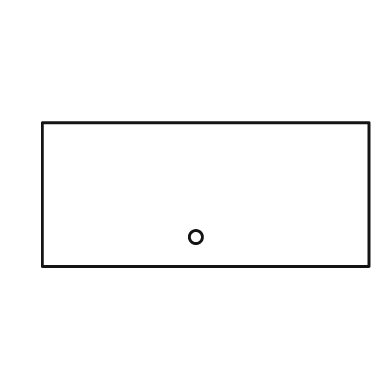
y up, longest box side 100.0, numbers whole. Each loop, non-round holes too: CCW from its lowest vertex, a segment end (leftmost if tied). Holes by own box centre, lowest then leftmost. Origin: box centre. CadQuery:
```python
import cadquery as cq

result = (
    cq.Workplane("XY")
    .moveTo(-50.0, -22.0)
    .lineTo(50.0, -22.0)
    .lineTo(50.0, 22.0)
    .lineTo(-50.0, 22.0)
    .close()
    .moveTo(-3.0, -13.0)
    .circle(2.0)
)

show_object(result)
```